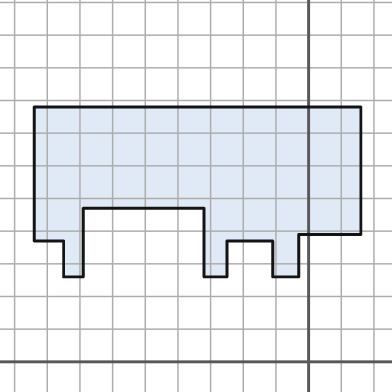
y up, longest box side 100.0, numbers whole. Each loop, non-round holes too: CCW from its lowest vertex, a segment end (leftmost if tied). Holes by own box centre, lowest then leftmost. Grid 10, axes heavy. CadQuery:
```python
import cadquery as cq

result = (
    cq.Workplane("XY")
    .moveTo(-75.0, 26.0)
    .lineTo(-69.0, 26.0)
    .lineTo(-69.0, 47.0)
    .lineTo(-32.0, 47.0)
    .lineTo(-32.0, 26.0)
    .lineTo(-25.0, 26.0)
    .lineTo(-25.0, 37.0)
    .lineTo(-11.0, 37.0)
    .lineTo(-11.0, 26.0)
    .lineTo(-3.0, 26.0)
    .lineTo(-3.0, 39.0)
    .lineTo(16.0, 39.0)
    .lineTo(16.0, 78.0)
    .lineTo(-84.0, 78.0)
    .lineTo(-84.0, 37.0)
    .lineTo(-75.0, 37.0)
    .close()
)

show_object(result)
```